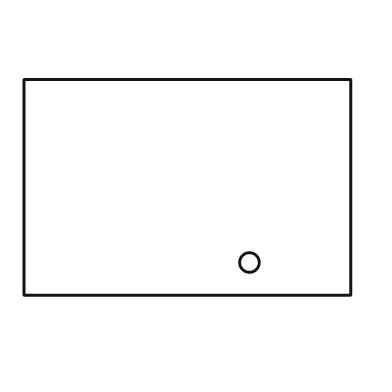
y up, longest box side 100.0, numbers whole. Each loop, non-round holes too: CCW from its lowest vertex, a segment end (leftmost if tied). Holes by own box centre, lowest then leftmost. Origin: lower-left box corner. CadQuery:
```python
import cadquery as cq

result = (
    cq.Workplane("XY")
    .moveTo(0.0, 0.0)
    .lineTo(100.0, 0.0)
    .lineTo(100.0, 66.0)
    .lineTo(0.0, 66.0)
    .close()
    .moveTo(69.0, 10.0)
    .circle(3.0)
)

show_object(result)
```